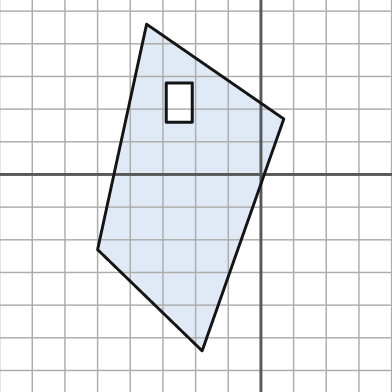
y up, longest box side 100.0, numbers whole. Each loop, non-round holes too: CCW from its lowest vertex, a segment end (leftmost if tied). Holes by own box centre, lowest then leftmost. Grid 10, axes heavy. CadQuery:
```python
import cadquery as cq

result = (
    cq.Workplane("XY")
    .moveTo(-18.0, -54.0)
    .lineTo(7.0, 17.0)
    .lineTo(-35.0, 46.0)
    .lineTo(-50.0, -23.0)
    .close()
    .moveTo(-29.0, 16.0)
    .lineTo(-21.0, 16.0)
    .lineTo(-21.0, 28.0)
    .lineTo(-29.0, 28.0)
    .close()
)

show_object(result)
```